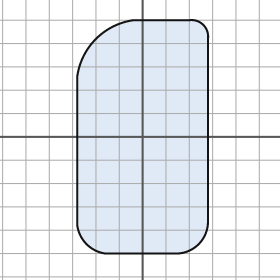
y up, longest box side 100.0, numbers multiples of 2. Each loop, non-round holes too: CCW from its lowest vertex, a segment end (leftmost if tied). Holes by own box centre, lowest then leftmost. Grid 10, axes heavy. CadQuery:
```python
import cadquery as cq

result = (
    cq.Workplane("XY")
    .moveTo(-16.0, -50.0)
    .lineTo(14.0, -50.0)
    .threePointArc((24.0, -46.0), (28.0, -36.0))
    .lineTo(28.0, 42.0)
    .threePointArc((26.0, 48.0), (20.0, 50.0))
    .lineTo(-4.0, 50.0)
    .threePointArc((-20.0, 42.0), (-28.0, 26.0))
    .lineTo(-28.0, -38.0)
    .threePointArc((-24.0, -46.0), (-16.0, -50.0))
    .close()
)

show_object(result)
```